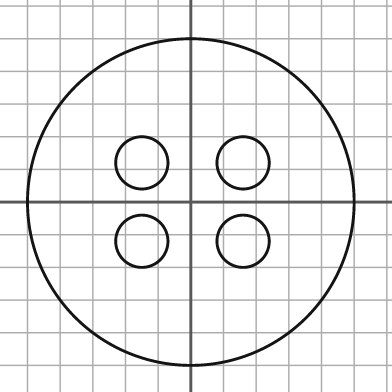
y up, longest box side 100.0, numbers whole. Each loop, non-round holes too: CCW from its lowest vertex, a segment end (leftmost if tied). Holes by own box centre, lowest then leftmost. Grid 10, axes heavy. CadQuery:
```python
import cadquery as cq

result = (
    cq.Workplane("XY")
    .moveTo(0.0, 0.0)
    .circle(50.0)
    .moveTo(-15.0, -12.0)
    .circle(8.0)
    .moveTo(16.0, -12.0)
    .circle(8.0)
    .moveTo(-15.0, 12.0)
    .circle(8.0)
    .moveTo(16.0, 12.0)
    .circle(8.0)
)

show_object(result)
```